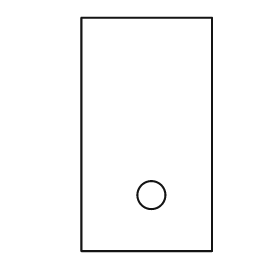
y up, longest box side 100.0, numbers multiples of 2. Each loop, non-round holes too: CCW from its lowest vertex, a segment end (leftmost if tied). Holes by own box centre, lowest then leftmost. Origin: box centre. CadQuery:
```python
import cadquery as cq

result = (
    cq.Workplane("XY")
    .moveTo(-28.0, -50.0)
    .lineTo(28.0, -50.0)
    .lineTo(28.0, 50.0)
    .lineTo(-28.0, 50.0)
    .close()
    .moveTo(2.0, -26.0)
    .circle(6.0)
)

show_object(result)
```